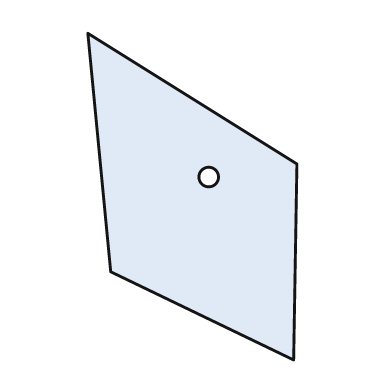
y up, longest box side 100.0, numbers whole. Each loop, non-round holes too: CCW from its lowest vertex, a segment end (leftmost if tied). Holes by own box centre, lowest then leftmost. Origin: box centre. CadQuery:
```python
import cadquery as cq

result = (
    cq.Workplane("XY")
    .moveTo(31.0, -50.0)
    .lineTo(32.0, 10.0)
    .lineTo(-32.0, 50.0)
    .lineTo(-25.0, -23.0)
    .close()
    .moveTo(5.0, 6.0)
    .circle(3.0)
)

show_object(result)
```